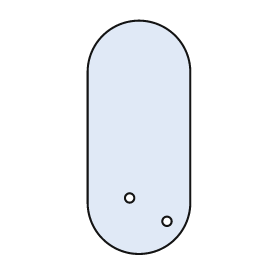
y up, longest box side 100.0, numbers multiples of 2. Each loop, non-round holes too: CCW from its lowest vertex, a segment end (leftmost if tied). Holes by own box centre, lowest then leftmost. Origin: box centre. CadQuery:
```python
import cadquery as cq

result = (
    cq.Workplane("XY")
    .moveTo(-22.0, -28.0)
    .threePointArc((0.0, -50.0), (22.0, -28.0))
    .lineTo(22.0, 28.0)
    .threePointArc((0.0, 50.0), (-22.0, 28.0))
    .close()
    .moveTo(12.0, -36.0)
    .circle(2.0)
    .moveTo(-4.0, -26.0)
    .circle(2.0)
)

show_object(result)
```